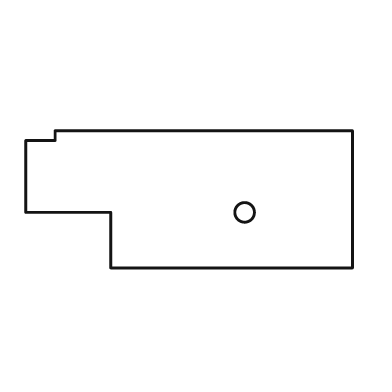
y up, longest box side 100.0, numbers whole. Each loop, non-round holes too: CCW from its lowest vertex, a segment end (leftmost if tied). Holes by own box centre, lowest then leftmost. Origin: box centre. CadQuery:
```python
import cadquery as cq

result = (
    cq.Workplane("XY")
    .moveTo(-24.0, -21.0)
    .lineTo(50.0, -21.0)
    .lineTo(50.0, 21.0)
    .lineTo(-41.0, 21.0)
    .lineTo(-41.0, 18.0)
    .lineTo(-50.0, 18.0)
    .lineTo(-50.0, -4.0)
    .lineTo(-24.0, -4.0)
    .close()
    .moveTo(17.0, -4.0)
    .circle(3.0)
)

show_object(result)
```